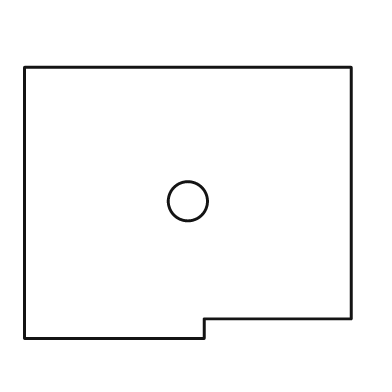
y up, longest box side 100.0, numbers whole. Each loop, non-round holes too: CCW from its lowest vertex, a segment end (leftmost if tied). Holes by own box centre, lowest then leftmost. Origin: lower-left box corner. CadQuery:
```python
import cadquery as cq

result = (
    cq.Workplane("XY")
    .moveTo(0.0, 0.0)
    .lineTo(55.0, 0.0)
    .lineTo(55.0, 6.0)
    .lineTo(100.0, 6.0)
    .lineTo(100.0, 83.0)
    .lineTo(0.0, 83.0)
    .close()
    .moveTo(50.0, 42.0)
    .circle(6.0)
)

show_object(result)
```